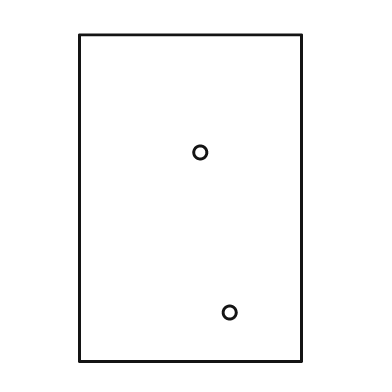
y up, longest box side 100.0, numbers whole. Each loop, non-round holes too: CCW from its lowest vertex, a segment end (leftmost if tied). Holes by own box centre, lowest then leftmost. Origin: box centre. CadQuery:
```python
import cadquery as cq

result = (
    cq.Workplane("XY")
    .moveTo(-34.0, -50.0)
    .lineTo(34.0, -50.0)
    .lineTo(34.0, 50.0)
    .lineTo(-34.0, 50.0)
    .close()
    .moveTo(12.0, -35.0)
    .circle(2.0)
    .moveTo(3.0, 14.0)
    .circle(2.0)
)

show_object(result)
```